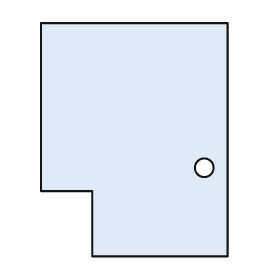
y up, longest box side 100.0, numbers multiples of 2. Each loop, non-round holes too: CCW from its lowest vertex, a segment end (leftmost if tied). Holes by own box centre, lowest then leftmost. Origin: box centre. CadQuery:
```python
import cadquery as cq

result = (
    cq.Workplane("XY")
    .moveTo(-18.0, -50.0)
    .lineTo(40.0, -50.0)
    .lineTo(40.0, 50.0)
    .lineTo(-40.0, 50.0)
    .lineTo(-40.0, -22.0)
    .lineTo(-18.0, -22.0)
    .close()
    .moveTo(30.0, -12.0)
    .circle(4.0)
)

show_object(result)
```